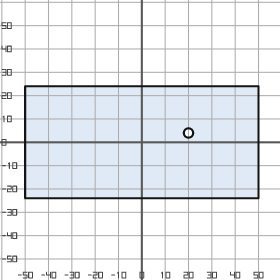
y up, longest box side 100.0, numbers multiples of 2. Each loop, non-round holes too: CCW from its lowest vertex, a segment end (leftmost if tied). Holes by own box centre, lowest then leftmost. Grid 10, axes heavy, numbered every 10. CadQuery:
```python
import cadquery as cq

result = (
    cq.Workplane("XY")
    .moveTo(-50.0, -24.0)
    .lineTo(50.0, -24.0)
    .lineTo(50.0, 24.0)
    .lineTo(-50.0, 24.0)
    .close()
    .moveTo(20.0, 4.0)
    .circle(2.0)
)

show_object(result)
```